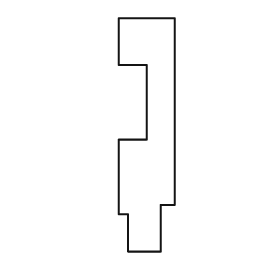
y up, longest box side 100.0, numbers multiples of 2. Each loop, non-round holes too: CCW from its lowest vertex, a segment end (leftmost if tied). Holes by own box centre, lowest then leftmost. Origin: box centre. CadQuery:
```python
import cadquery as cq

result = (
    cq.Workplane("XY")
    .moveTo(-8.0, -50.0)
    .lineTo(6.0, -50.0)
    .lineTo(6.0, -30.0)
    .lineTo(12.0, -30.0)
    .lineTo(12.0, 50.0)
    .lineTo(-12.0, 50.0)
    .lineTo(-12.0, 30.0)
    .lineTo(0.0, 30.0)
    .lineTo(0.0, -2.0)
    .lineTo(-12.0, -2.0)
    .lineTo(-12.0, -34.0)
    .lineTo(-8.0, -34.0)
    .close()
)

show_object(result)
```